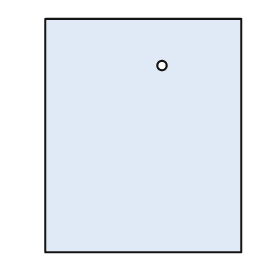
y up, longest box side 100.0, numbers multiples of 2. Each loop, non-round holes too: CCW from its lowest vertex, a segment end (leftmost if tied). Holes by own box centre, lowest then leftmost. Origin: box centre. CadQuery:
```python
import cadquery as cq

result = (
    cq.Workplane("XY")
    .moveTo(-42.0, -50.0)
    .lineTo(42.0, -50.0)
    .lineTo(42.0, 50.0)
    .lineTo(-42.0, 50.0)
    .close()
    .moveTo(8.0, 30.0)
    .circle(2.0)
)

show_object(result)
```